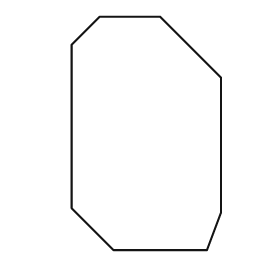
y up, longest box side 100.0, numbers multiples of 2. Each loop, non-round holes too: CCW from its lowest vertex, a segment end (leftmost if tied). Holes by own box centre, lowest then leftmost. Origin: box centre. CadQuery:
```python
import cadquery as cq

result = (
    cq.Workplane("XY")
    .moveTo(-14.0, -50.0)
    .lineTo(26.0, -50.0)
    .lineTo(32.0, -34.0)
    .lineTo(32.0, 24.0)
    .lineTo(6.0, 50.0)
    .lineTo(-20.0, 50.0)
    .lineTo(-32.0, 38.0)
    .lineTo(-32.0, -32.0)
    .close()
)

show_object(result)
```